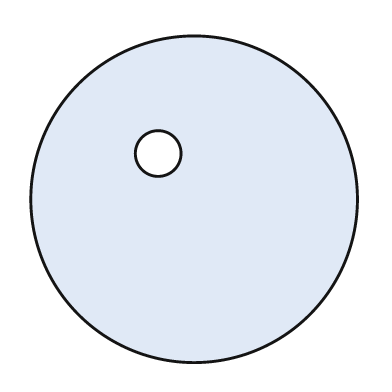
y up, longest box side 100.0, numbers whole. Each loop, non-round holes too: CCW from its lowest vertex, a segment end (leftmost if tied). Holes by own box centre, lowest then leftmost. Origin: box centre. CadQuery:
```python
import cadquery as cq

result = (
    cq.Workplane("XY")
    .moveTo(0.0, 0.0)
    .circle(50.0)
    .moveTo(-11.0, 14.0)
    .circle(7.0)
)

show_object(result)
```